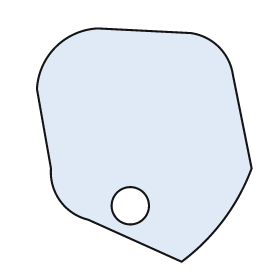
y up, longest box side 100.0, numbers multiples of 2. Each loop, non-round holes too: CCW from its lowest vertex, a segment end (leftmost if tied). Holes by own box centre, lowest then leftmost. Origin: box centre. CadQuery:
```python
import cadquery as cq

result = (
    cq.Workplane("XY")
    .moveTo(16.0, -50.0)
    .threePointArc((34.0, -32.0), (46.0, -10.0))
    .lineTo(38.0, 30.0)
    .threePointArc((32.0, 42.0), (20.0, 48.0))
    .lineTo(-20.0, 50.0)
    .threePointArc((-38.0, 42.0), (-46.0, 24.0))
    .lineTo(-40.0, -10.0)
    .threePointArc((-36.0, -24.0), (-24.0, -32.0))
    .close()
    .moveTo(-6.0, -26.0)
    .circle(8.0)
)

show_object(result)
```